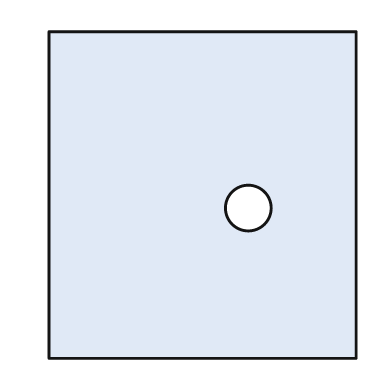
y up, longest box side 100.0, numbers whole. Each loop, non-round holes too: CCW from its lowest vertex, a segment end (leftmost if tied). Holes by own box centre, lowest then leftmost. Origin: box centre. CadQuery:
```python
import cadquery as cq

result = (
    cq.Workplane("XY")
    .moveTo(-47.0, -50.0)
    .lineTo(47.0, -50.0)
    .lineTo(47.0, 50.0)
    .lineTo(-47.0, 50.0)
    .close()
    .moveTo(14.0, -4.0)
    .circle(7.0)
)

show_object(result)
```